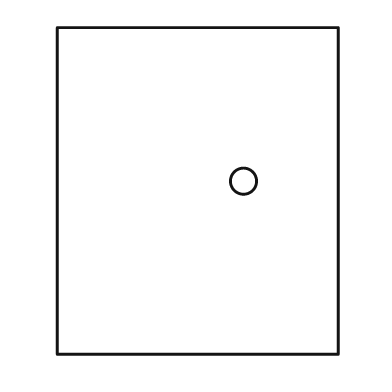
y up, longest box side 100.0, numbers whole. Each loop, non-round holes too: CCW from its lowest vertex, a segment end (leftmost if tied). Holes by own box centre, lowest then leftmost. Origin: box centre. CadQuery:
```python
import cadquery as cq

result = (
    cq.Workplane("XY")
    .moveTo(-43.0, -50.0)
    .lineTo(43.0, -50.0)
    .lineTo(43.0, 50.0)
    .lineTo(-43.0, 50.0)
    .close()
    .moveTo(14.0, 3.0)
    .circle(4.0)
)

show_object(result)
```